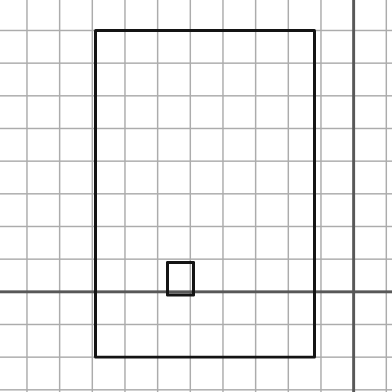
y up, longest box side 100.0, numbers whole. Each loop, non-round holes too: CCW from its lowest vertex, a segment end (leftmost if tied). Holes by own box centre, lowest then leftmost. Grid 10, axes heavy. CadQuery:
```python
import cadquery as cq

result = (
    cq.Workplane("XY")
    .moveTo(-79.0, -20.0)
    .lineTo(-12.0, -20.0)
    .lineTo(-12.0, 80.0)
    .lineTo(-79.0, 80.0)
    .close()
    .moveTo(-57.0, -1.0)
    .lineTo(-49.0, -1.0)
    .lineTo(-49.0, 9.0)
    .lineTo(-57.0, 9.0)
    .close()
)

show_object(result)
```